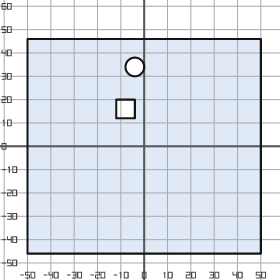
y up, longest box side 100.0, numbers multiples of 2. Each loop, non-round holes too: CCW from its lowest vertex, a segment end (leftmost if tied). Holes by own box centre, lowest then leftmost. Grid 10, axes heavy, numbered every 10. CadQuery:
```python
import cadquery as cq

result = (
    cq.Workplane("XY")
    .moveTo(-50.0, -46.0)
    .lineTo(50.0, -46.0)
    .lineTo(50.0, 46.0)
    .lineTo(-50.0, 46.0)
    .close()
    .moveTo(-12.0, 12.0)
    .lineTo(-4.0, 12.0)
    .lineTo(-4.0, 20.0)
    .lineTo(-12.0, 20.0)
    .close()
    .moveTo(-4.0, 34.0)
    .circle(4.0)
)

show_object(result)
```